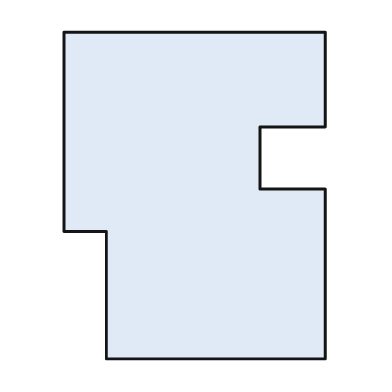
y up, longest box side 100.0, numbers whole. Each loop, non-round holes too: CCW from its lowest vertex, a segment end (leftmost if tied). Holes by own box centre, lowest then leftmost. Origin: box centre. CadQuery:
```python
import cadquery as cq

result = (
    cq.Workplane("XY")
    .moveTo(-27.0, -50.0)
    .lineTo(40.0, -50.0)
    .lineTo(40.0, 2.0)
    .lineTo(20.0, 2.0)
    .lineTo(20.0, 21.0)
    .lineTo(40.0, 21.0)
    .lineTo(40.0, 50.0)
    .lineTo(-40.0, 50.0)
    .lineTo(-40.0, -11.0)
    .lineTo(-27.0, -11.0)
    .close()
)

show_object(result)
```